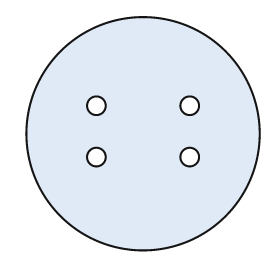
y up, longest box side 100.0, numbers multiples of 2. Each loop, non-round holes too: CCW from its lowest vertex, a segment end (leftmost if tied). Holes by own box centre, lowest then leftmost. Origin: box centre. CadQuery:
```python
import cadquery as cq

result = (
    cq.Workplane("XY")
    .moveTo(0.0, 0.0)
    .circle(50.0)
    .moveTo(-20.0, -10.0)
    .circle(4.0)
    .moveTo(20.0, -10.0)
    .circle(4.0)
    .moveTo(-20.0, 12.0)
    .circle(4.0)
    .moveTo(20.0, 12.0)
    .circle(4.0)
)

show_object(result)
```